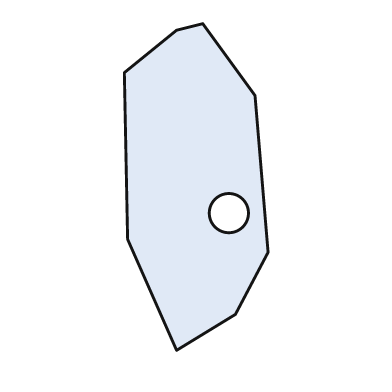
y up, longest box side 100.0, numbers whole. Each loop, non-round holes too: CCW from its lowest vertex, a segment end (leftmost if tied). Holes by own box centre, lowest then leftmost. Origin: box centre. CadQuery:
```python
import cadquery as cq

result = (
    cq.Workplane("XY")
    .moveTo(-6.0, -50.0)
    .lineTo(12.0, -39.0)
    .lineTo(22.0, -20.0)
    .lineTo(18.0, 28.0)
    .lineTo(2.0, 50.0)
    .lineTo(-6.0, 48.0)
    .lineTo(-22.0, 35.0)
    .lineTo(-21.0, -16.0)
    .close()
    .moveTo(10.0, -8.0)
    .circle(6.0)
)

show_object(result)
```